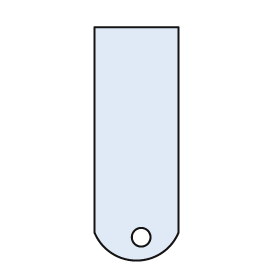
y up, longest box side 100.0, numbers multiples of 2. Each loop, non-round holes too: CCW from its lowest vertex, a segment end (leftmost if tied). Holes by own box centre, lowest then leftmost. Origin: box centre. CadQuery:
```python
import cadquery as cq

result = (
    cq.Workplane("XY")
    .moveTo(-18.0, -38.0)
    .threePointArc((0.0, -50.0), (18.0, -38.0))
    .lineTo(18.0, 50.0)
    .lineTo(-18.0, 50.0)
    .close()
    .moveTo(2.0, -40.0)
    .circle(4.0)
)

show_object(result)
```